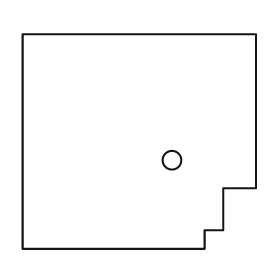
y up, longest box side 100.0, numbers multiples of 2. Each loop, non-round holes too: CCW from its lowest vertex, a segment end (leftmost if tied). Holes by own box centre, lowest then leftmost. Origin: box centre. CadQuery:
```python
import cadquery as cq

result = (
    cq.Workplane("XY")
    .moveTo(-50.0, -46.0)
    .lineTo(28.0, -46.0)
    .lineTo(28.0, -38.0)
    .lineTo(36.0, -38.0)
    .lineTo(36.0, -20.0)
    .lineTo(50.0, -20.0)
    .lineTo(50.0, 46.0)
    .lineTo(-50.0, 46.0)
    .close()
    .moveTo(14.0, -8.0)
    .circle(4.0)
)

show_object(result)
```